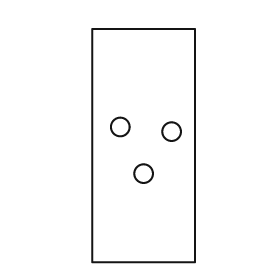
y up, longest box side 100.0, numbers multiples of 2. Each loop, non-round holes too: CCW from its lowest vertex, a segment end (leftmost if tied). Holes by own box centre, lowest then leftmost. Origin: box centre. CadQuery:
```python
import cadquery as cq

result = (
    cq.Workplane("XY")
    .moveTo(-22.0, -50.0)
    .lineTo(22.0, -50.0)
    .lineTo(22.0, 50.0)
    .lineTo(-22.0, 50.0)
    .close()
    .moveTo(0.0, -12.0)
    .circle(4.0)
    .moveTo(12.0, 6.0)
    .circle(4.0)
    .moveTo(-10.0, 8.0)
    .circle(4.0)
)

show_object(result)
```